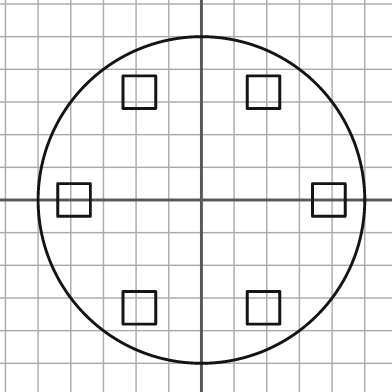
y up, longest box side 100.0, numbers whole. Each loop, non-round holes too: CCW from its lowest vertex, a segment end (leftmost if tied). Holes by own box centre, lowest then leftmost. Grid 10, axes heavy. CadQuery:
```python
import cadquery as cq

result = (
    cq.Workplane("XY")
    .moveTo(0.0, 0.0)
    .circle(50.0)
    .moveTo(-24.0, -38.0)
    .lineTo(-14.0, -38.0)
    .lineTo(-14.0, -28.0)
    .lineTo(-24.0, -28.0)
    .close()
    .moveTo(14.0, -38.0)
    .lineTo(24.0, -38.0)
    .lineTo(24.0, -28.0)
    .lineTo(14.0, -28.0)
    .close()
    .moveTo(-44.0, -5.0)
    .lineTo(-34.0, -5.0)
    .lineTo(-34.0, 5.0)
    .lineTo(-44.0, 5.0)
    .close()
    .moveTo(34.0, -5.0)
    .lineTo(44.0, -5.0)
    .lineTo(44.0, 5.0)
    .lineTo(34.0, 5.0)
    .close()
    .moveTo(-24.0, 28.0)
    .lineTo(-14.0, 28.0)
    .lineTo(-14.0, 38.0)
    .lineTo(-24.0, 38.0)
    .close()
    .moveTo(14.0, 28.0)
    .lineTo(24.0, 28.0)
    .lineTo(24.0, 38.0)
    .lineTo(14.0, 38.0)
    .close()
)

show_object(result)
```